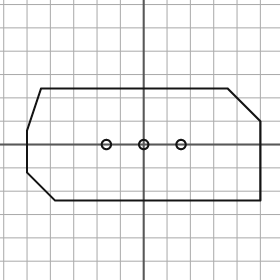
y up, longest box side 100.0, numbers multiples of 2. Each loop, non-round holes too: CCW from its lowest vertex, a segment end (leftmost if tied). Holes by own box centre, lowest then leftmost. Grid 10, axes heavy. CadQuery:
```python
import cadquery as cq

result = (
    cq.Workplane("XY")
    .moveTo(-38.0, -24.0)
    .lineTo(50.0, -24.0)
    .lineTo(50.0, 10.0)
    .lineTo(36.0, 24.0)
    .lineTo(-44.0, 24.0)
    .lineTo(-50.0, 6.0)
    .lineTo(-50.0, -12.0)
    .close()
    .moveTo(-16.0, 0.0)
    .circle(2.0)
    .moveTo(0.0, 0.0)
    .circle(2.0)
    .moveTo(16.0, 0.0)
    .circle(2.0)
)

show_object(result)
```